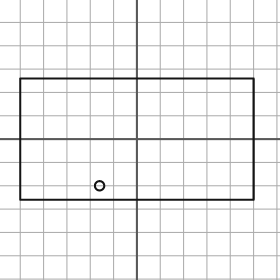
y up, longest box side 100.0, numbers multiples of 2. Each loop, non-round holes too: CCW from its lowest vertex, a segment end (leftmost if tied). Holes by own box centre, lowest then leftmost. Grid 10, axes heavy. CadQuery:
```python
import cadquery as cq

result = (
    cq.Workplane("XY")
    .moveTo(-50.0, -26.0)
    .lineTo(50.0, -26.0)
    .lineTo(50.0, 26.0)
    .lineTo(-50.0, 26.0)
    .close()
    .moveTo(-16.0, -20.0)
    .circle(2.0)
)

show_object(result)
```